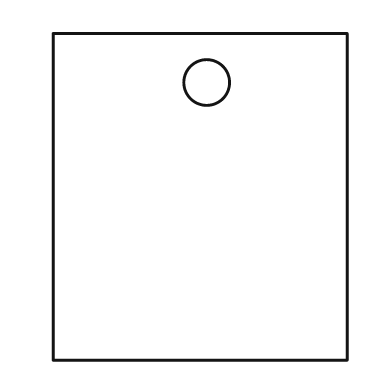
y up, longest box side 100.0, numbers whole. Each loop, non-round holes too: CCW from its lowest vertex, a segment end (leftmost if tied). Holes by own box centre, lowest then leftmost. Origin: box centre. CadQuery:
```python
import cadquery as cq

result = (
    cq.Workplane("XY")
    .moveTo(-45.0, -50.0)
    .lineTo(45.0, -50.0)
    .lineTo(45.0, 50.0)
    .lineTo(-45.0, 50.0)
    .close()
    .moveTo(2.0, 35.0)
    .circle(7.0)
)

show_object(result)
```